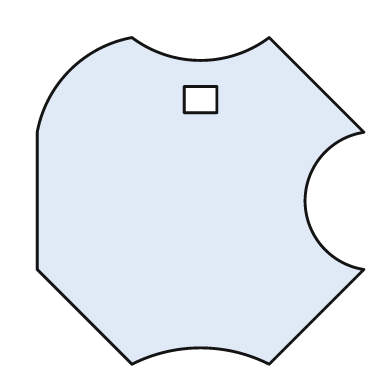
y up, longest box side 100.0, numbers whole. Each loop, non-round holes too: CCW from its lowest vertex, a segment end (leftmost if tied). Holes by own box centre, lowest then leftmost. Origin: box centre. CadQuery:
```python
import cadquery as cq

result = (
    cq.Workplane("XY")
    .moveTo(-21.0, -50.0)
    .threePointArc((0.0, -45.0), (21.0, -50.0))
    .lineTo(50.0, -21.0)
    .threePointArc((32.0, 0.0), (50.0, 21.0))
    .lineTo(21.0, 50.0)
    .threePointArc((0.0, 43.0), (-21.0, 50.0))
    .threePointArc((-40.0, 40.0), (-50.0, 21.0))
    .lineTo(-50.0, -21.0)
    .close()
    .moveTo(-5.0, 27.0)
    .lineTo(5.0, 27.0)
    .lineTo(5.0, 35.0)
    .lineTo(-5.0, 35.0)
    .close()
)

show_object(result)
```